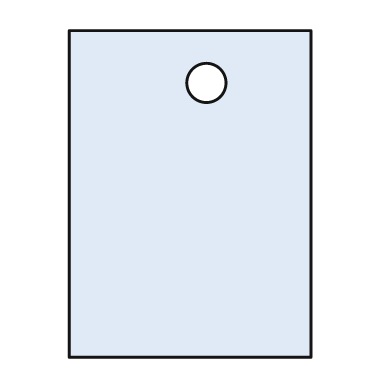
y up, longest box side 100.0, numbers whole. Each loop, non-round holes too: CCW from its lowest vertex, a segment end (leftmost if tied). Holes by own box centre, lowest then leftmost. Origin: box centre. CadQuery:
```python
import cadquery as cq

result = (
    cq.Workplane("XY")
    .moveTo(-37.0, -50.0)
    .lineTo(37.0, -50.0)
    .lineTo(37.0, 50.0)
    .lineTo(-37.0, 50.0)
    .close()
    .moveTo(5.0, 34.0)
    .circle(6.0)
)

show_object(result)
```